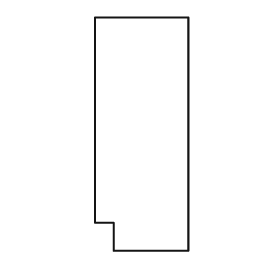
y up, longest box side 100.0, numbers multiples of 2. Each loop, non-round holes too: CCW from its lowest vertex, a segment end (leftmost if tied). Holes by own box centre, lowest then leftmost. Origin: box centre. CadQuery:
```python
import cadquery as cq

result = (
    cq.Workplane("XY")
    .moveTo(-12.0, -50.0)
    .lineTo(20.0, -50.0)
    .lineTo(20.0, 50.0)
    .lineTo(-20.0, 50.0)
    .lineTo(-20.0, -38.0)
    .lineTo(-12.0, -38.0)
    .close()
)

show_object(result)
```